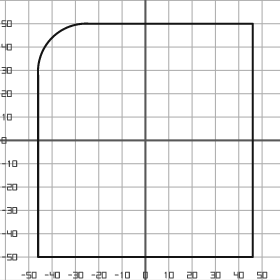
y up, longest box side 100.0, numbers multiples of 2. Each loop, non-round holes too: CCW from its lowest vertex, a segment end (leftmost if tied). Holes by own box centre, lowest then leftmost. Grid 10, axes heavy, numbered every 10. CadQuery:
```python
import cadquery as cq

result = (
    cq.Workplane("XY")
    .moveTo(-46.0, -50.0)
    .lineTo(46.0, -50.0)
    .lineTo(46.0, 50.0)
    .lineTo(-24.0, 50.0)
    .threePointArc((-40.0, 44.0), (-46.0, 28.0))
    .close()
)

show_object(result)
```